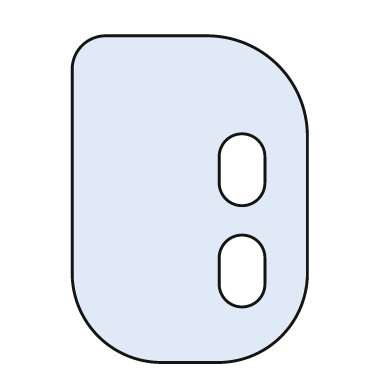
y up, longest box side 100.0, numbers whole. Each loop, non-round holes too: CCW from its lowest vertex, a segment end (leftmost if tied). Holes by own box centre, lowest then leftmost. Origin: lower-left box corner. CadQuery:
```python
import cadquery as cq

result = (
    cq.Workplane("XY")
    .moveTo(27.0, 0.0)
    .lineTo(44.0, 0.0)
    .threePointArc((64.0, 8.0), (72.0, 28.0))
    .lineTo(72.0, 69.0)
    .threePointArc((63.0, 91.0), (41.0, 100.0))
    .lineTo(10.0, 100.0)
    .threePointArc((3.0, 97.0), (0.0, 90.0))
    .lineTo(0.0, 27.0)
    .threePointArc((8.0, 8.0), (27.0, 0.0))
    .close()
    .moveTo(45.0, 24.0)
    .threePointArc((52.0, 17.0), (59.0, 24.0))
    .lineTo(59.0, 32.0)
    .threePointArc((52.0, 39.0), (45.0, 32.0))
    .close()
    .moveTo(45.0, 55.0)
    .threePointArc((52.0, 48.0), (59.0, 55.0))
    .lineTo(59.0, 63.0)
    .threePointArc((52.0, 70.0), (45.0, 63.0))
    .close()
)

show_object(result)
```